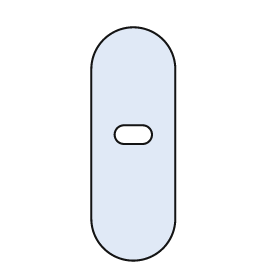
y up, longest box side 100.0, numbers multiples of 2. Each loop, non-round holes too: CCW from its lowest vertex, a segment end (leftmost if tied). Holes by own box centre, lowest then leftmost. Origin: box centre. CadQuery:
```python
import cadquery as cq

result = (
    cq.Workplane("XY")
    .moveTo(-18.0, -32.0)
    .threePointArc((0.0, -50.0), (18.0, -32.0))
    .lineTo(18.0, 32.0)
    .threePointArc((0.0, 50.0), (-18.0, 32.0))
    .close()
    .moveTo(-4.0, 0.0)
    .lineTo(4.0, 0.0)
    .threePointArc((8.0, 4.0), (4.0, 8.0))
    .lineTo(-4.0, 8.0)
    .threePointArc((-8.0, 4.0), (-4.0, 0.0))
    .close()
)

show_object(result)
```